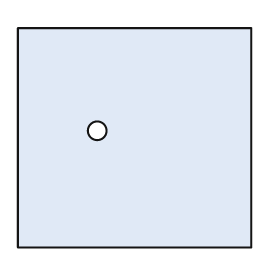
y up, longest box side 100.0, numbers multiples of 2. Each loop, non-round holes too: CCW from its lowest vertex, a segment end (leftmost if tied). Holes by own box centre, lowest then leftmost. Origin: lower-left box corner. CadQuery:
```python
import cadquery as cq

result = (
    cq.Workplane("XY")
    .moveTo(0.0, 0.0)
    .lineTo(100.0, 0.0)
    .lineTo(100.0, 94.0)
    .lineTo(0.0, 94.0)
    .close()
    .moveTo(34.0, 50.0)
    .circle(4.0)
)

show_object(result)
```